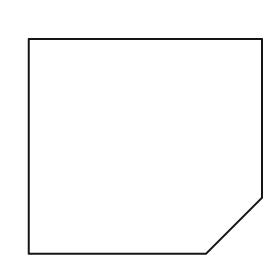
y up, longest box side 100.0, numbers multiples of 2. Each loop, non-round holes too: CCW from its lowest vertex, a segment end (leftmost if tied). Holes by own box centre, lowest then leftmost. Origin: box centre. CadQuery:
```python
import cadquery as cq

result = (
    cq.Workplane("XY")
    .moveTo(-50.0, -46.0)
    .lineTo(26.0, -46.0)
    .lineTo(50.0, -22.0)
    .lineTo(50.0, 46.0)
    .lineTo(-50.0, 46.0)
    .close()
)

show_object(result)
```